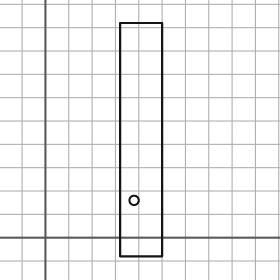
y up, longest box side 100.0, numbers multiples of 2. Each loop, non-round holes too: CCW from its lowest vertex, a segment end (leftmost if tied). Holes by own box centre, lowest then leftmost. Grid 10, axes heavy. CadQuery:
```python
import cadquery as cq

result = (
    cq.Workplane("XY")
    .moveTo(32.0, -8.0)
    .lineTo(50.0, -8.0)
    .lineTo(50.0, 92.0)
    .lineTo(32.0, 92.0)
    .close()
    .moveTo(38.0, 16.0)
    .circle(2.0)
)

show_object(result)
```